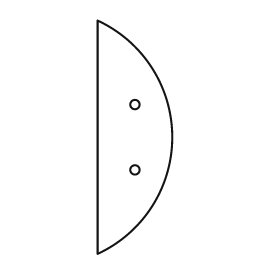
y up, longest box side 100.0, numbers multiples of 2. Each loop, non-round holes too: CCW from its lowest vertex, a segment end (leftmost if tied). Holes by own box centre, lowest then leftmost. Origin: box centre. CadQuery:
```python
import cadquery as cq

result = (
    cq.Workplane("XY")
    .moveTo(-16.0, -50.0)
    .threePointArc((16.0, 0.0), (-16.0, 50.0))
    .close()
    .moveTo(0.0, -14.0)
    .circle(2.0)
    .moveTo(0.0, 14.0)
    .circle(2.0)
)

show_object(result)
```